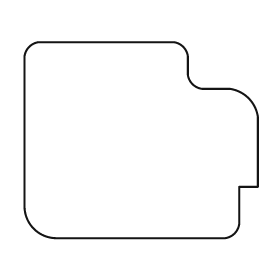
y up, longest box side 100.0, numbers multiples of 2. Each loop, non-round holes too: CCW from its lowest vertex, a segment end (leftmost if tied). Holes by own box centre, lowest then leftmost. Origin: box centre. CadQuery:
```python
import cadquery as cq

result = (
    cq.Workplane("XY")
    .moveTo(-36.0, -42.0)
    .lineTo(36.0, -42.0)
    .threePointArc((40.0, -40.0), (42.0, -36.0))
    .lineTo(42.0, -20.0)
    .lineTo(50.0, -20.0)
    .lineTo(50.0, 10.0)
    .threePointArc((46.0, 18.0), (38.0, 22.0))
    .lineTo(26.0, 22.0)
    .threePointArc((22.0, 24.0), (20.0, 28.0))
    .lineTo(20.0, 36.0)
    .threePointArc((18.0, 40.0), (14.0, 42.0))
    .lineTo(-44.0, 42.0)
    .threePointArc((-48.0, 40.0), (-50.0, 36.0))
    .lineTo(-50.0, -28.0)
    .threePointArc((-46.0, -38.0), (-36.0, -42.0))
    .close()
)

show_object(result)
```